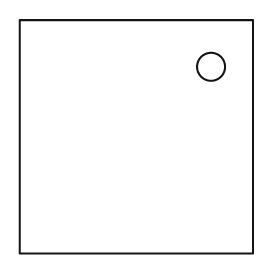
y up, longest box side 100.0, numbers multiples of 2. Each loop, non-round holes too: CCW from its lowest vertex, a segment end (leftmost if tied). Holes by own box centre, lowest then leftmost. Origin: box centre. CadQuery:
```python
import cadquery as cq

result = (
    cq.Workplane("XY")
    .moveTo(-50.0, -50.0)
    .lineTo(50.0, -50.0)
    .lineTo(50.0, 50.0)
    .lineTo(-50.0, 50.0)
    .close()
    .moveTo(32.0, 30.0)
    .circle(6.0)
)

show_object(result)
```